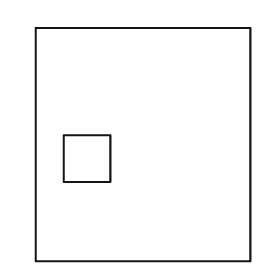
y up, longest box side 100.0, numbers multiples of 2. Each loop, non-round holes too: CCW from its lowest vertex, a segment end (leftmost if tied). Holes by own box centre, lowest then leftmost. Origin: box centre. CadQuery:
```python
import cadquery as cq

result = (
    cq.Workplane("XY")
    .moveTo(-46.0, -50.0)
    .lineTo(46.0, -50.0)
    .lineTo(46.0, 50.0)
    .lineTo(-46.0, 50.0)
    .close()
    .moveTo(-34.0, -16.0)
    .lineTo(-14.0, -16.0)
    .lineTo(-14.0, 4.0)
    .lineTo(-34.0, 4.0)
    .close()
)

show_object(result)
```